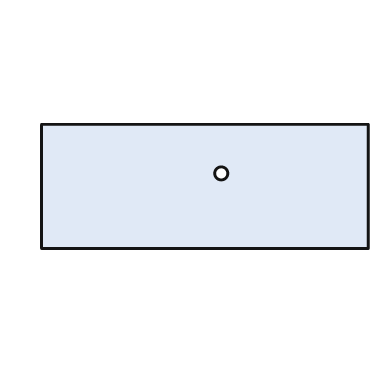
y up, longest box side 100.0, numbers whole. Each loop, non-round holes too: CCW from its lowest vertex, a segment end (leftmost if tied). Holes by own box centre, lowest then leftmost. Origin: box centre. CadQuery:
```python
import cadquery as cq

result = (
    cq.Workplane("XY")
    .moveTo(-50.0, -19.0)
    .lineTo(50.0, -19.0)
    .lineTo(50.0, 19.0)
    .lineTo(-50.0, 19.0)
    .close()
    .moveTo(5.0, 4.0)
    .circle(2.0)
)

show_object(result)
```